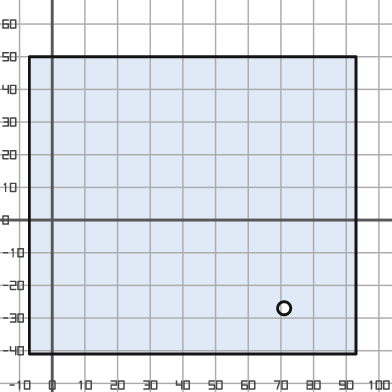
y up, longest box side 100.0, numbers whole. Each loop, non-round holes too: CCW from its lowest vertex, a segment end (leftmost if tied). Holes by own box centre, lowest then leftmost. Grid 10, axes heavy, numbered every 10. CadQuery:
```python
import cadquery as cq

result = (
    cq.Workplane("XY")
    .moveTo(-7.0, -41.0)
    .lineTo(93.0, -41.0)
    .lineTo(93.0, 50.0)
    .lineTo(-7.0, 50.0)
    .close()
    .moveTo(71.0, -27.0)
    .circle(2.0)
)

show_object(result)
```